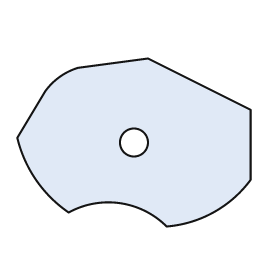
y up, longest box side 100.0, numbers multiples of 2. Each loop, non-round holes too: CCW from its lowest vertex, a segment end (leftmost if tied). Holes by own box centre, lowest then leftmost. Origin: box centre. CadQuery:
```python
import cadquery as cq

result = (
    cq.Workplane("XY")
    .moveTo(14.0, -36.0)
    .threePointArc((34.0, -30.0), (50.0, -16.0))
    .lineTo(50.0, 14.0)
    .lineTo(6.0, 36.0)
    .lineTo(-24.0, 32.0)
    .threePointArc((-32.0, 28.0), (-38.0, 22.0))
    .lineTo(-50.0, 2.0)
    .threePointArc((-42.0, -16.0), (-28.0, -30.0))
    .threePointArc((-6.0, -26.0), (14.0, -36.0))
    .close()
    .moveTo(0.0, 0.0)
    .circle(6.0)
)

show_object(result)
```